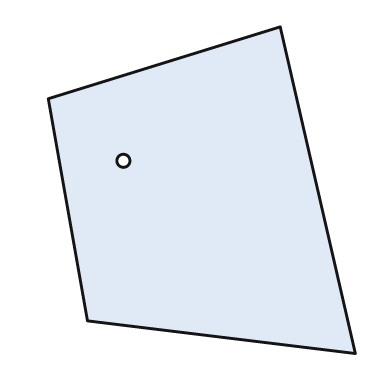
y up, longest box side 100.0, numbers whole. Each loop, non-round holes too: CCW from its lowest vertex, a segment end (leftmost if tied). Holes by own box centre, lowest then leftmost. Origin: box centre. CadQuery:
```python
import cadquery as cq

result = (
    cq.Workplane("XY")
    .moveTo(47.0, -50.0)
    .lineTo(24.0, 50.0)
    .lineTo(-47.0, 28.0)
    .lineTo(-35.0, -40.0)
    .close()
    .moveTo(-24.0, 9.0)
    .circle(2.0)
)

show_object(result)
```